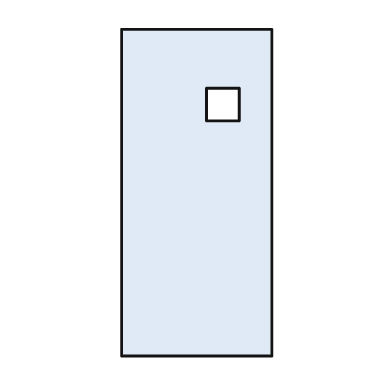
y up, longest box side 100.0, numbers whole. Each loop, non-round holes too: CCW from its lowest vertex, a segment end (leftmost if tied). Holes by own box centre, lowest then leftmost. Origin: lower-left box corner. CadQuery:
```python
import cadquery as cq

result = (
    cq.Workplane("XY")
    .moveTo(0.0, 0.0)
    .lineTo(46.0, 0.0)
    .lineTo(46.0, 100.0)
    .lineTo(0.0, 100.0)
    .close()
    .moveTo(26.0, 72.0)
    .lineTo(36.0, 72.0)
    .lineTo(36.0, 82.0)
    .lineTo(26.0, 82.0)
    .close()
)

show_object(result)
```